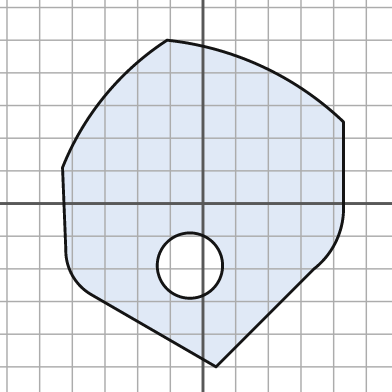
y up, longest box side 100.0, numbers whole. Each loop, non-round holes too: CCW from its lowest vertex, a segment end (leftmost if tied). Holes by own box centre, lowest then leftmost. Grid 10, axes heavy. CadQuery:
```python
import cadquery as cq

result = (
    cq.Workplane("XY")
    .moveTo(4.0, -50.0)
    .lineTo(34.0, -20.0)
    .threePointArc((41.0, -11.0), (43.0, 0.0))
    .lineTo(43.0, 25.0)
    .threePointArc((18.0, 42.0), (-11.0, 50.0))
    .threePointArc((-30.0, 33.0), (-43.0, 11.0))
    .lineTo(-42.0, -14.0)
    .threePointArc((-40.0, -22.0), (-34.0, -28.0))
    .close()
    .moveTo(-4.0, -19.0)
    .circle(10.0)
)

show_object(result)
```